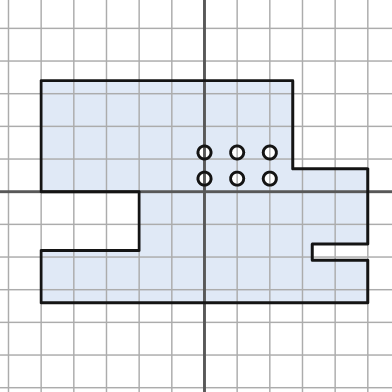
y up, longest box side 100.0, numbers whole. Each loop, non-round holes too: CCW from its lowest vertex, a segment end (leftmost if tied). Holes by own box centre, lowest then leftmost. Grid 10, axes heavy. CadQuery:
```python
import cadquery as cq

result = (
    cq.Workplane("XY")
    .moveTo(-50.0, -34.0)
    .lineTo(50.0, -34.0)
    .lineTo(50.0, -21.0)
    .lineTo(33.0, -21.0)
    .lineTo(33.0, -16.0)
    .lineTo(50.0, -16.0)
    .lineTo(50.0, 7.0)
    .lineTo(27.0, 7.0)
    .lineTo(27.0, 34.0)
    .lineTo(-50.0, 34.0)
    .lineTo(-50.0, 0.0)
    .lineTo(-20.0, 0.0)
    .lineTo(-20.0, -18.0)
    .lineTo(-50.0, -18.0)
    .close()
    .moveTo(0.0, 4.0)
    .circle(2.0)
    .moveTo(10.0, 4.0)
    .circle(2.0)
    .moveTo(20.0, 4.0)
    .circle(2.0)
    .moveTo(0.0, 12.0)
    .circle(2.0)
    .moveTo(10.0, 12.0)
    .circle(2.0)
    .moveTo(20.0, 12.0)
    .circle(2.0)
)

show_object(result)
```